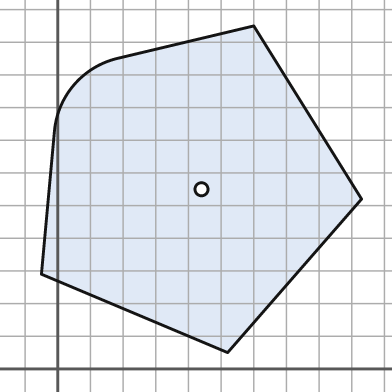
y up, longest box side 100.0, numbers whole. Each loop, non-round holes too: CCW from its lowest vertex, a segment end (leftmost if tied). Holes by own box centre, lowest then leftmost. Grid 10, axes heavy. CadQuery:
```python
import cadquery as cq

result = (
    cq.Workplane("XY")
    .moveTo(52.0, 5.0)
    .lineTo(93.0, 52.0)
    .lineTo(60.0, 105.0)
    .lineTo(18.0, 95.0)
    .threePointArc((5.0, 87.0), (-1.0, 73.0))
    .lineTo(-5.0, 29.0)
    .close()
    .moveTo(44.0, 55.0)
    .circle(2.0)
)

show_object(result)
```